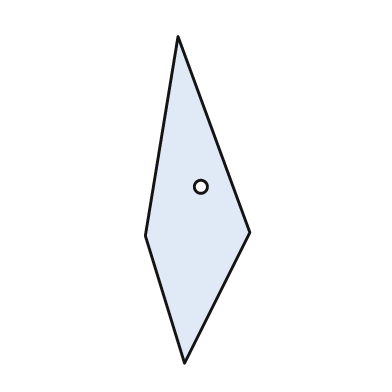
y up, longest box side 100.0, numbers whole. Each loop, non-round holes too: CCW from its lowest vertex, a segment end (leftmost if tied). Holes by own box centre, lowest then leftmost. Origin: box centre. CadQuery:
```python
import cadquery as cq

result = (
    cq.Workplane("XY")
    .moveTo(-4.0, -50.0)
    .lineTo(16.0, -10.0)
    .lineTo(-6.0, 50.0)
    .lineTo(-16.0, -11.0)
    .close()
    .moveTo(1.0, 4.0)
    .circle(2.0)
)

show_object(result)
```